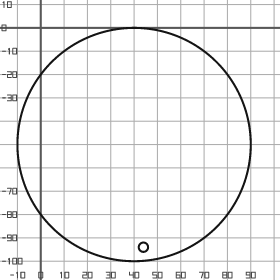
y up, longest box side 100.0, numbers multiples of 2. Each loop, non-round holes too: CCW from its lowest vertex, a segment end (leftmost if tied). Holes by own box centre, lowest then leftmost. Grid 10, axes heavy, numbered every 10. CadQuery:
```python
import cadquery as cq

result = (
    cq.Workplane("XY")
    .moveTo(40.0, -50.0)
    .circle(50.0)
    .moveTo(44.0, -94.0)
    .circle(2.0)
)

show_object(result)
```